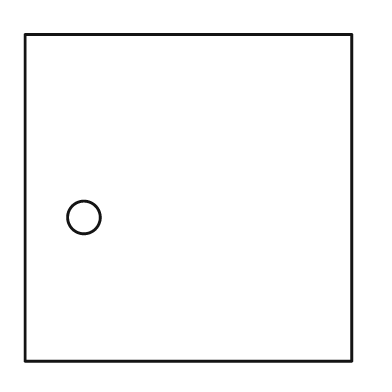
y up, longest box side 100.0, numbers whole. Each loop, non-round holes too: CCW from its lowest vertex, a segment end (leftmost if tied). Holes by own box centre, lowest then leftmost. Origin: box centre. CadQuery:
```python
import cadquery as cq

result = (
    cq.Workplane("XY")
    .moveTo(-50.0, -50.0)
    .lineTo(50.0, -50.0)
    .lineTo(50.0, 50.0)
    .lineTo(-50.0, 50.0)
    .close()
    .moveTo(-32.0, -6.0)
    .circle(5.0)
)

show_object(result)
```